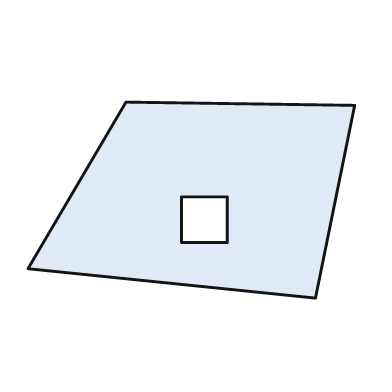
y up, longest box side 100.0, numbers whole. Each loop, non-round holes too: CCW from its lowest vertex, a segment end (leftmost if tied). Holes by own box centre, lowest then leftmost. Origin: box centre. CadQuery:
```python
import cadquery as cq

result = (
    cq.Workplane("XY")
    .moveTo(38.0, -30.0)
    .lineTo(50.0, 29.0)
    .lineTo(-20.0, 30.0)
    .lineTo(-50.0, -21.0)
    .close()
    .moveTo(-3.0, -13.0)
    .lineTo(11.0, -13.0)
    .lineTo(11.0, 1.0)
    .lineTo(-3.0, 1.0)
    .close()
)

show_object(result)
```